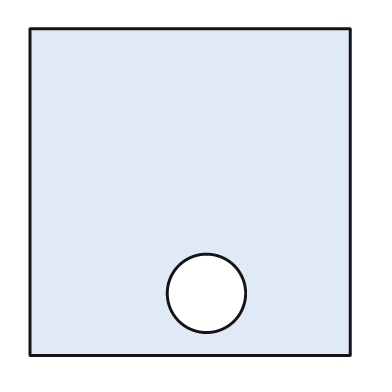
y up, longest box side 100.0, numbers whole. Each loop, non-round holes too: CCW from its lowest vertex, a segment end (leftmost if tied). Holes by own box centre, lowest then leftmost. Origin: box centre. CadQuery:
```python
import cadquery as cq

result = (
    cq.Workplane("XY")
    .moveTo(-49.0, -50.0)
    .lineTo(49.0, -50.0)
    .lineTo(49.0, 50.0)
    .lineTo(-49.0, 50.0)
    .close()
    .moveTo(5.0, -31.0)
    .circle(12.0)
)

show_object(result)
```